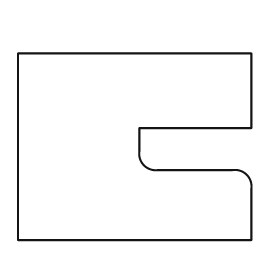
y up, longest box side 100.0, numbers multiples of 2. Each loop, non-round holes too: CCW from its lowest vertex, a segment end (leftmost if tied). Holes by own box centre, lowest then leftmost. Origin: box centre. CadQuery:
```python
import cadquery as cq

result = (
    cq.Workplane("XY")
    .moveTo(-50.0, -40.0)
    .lineTo(50.0, -40.0)
    .lineTo(50.0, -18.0)
    .threePointArc((48.0, -12.0), (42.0, -10.0))
    .lineTo(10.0, -10.0)
    .threePointArc((4.0, -8.0), (2.0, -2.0))
    .lineTo(2.0, 8.0)
    .lineTo(50.0, 8.0)
    .lineTo(50.0, 40.0)
    .lineTo(-50.0, 40.0)
    .close()
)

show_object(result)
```